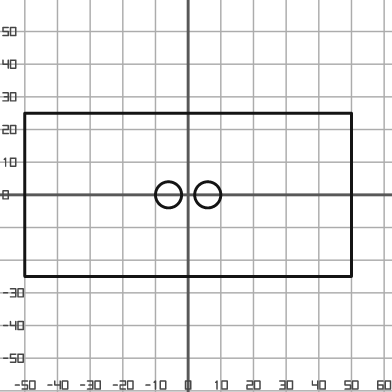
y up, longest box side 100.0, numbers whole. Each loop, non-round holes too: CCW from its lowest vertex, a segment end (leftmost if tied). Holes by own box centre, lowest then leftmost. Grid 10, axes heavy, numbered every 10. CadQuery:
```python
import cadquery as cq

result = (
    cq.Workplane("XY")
    .moveTo(-50.0, -25.0)
    .lineTo(50.0, -25.0)
    .lineTo(50.0, 25.0)
    .lineTo(-50.0, 25.0)
    .close()
    .moveTo(-6.0, 0.0)
    .circle(4.0)
    .moveTo(6.0, 0.0)
    .circle(4.0)
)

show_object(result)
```